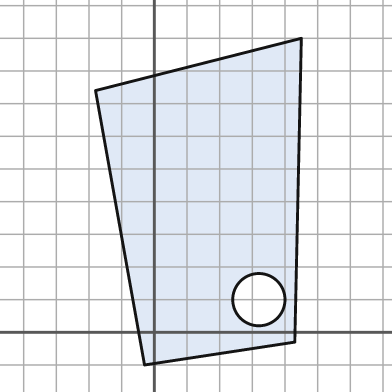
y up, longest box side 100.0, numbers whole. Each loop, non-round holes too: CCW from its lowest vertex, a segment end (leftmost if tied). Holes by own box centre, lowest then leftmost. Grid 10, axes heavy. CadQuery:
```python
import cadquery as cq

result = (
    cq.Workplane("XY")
    .moveTo(-3.0, -10.0)
    .lineTo(43.0, -3.0)
    .lineTo(45.0, 90.0)
    .lineTo(-18.0, 74.0)
    .close()
    .moveTo(32.0, 10.0)
    .circle(8.0)
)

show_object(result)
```